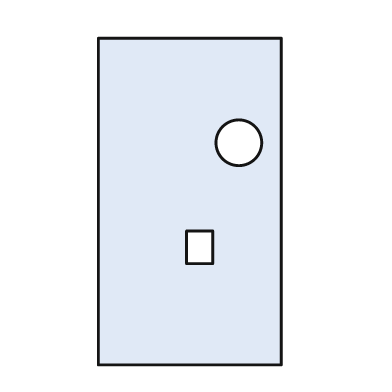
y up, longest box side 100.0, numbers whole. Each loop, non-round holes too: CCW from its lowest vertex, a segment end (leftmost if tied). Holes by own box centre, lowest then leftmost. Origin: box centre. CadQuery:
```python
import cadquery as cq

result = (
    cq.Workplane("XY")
    .moveTo(-28.0, -50.0)
    .lineTo(28.0, -50.0)
    .lineTo(28.0, 50.0)
    .lineTo(-28.0, 50.0)
    .close()
    .moveTo(-1.0, -19.0)
    .lineTo(7.0, -19.0)
    .lineTo(7.0, -9.0)
    .lineTo(-1.0, -9.0)
    .close()
    .moveTo(15.0, 18.0)
    .circle(7.0)
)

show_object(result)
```